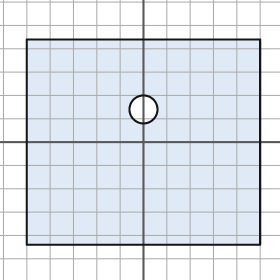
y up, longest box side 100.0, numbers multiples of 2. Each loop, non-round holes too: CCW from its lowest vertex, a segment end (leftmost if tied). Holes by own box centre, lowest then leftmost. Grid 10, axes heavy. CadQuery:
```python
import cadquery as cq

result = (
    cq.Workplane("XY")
    .moveTo(-50.0, -44.0)
    .lineTo(50.0, -44.0)
    .lineTo(50.0, 44.0)
    .lineTo(-50.0, 44.0)
    .close()
    .moveTo(0.0, 14.0)
    .circle(6.0)
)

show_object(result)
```